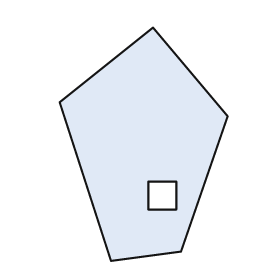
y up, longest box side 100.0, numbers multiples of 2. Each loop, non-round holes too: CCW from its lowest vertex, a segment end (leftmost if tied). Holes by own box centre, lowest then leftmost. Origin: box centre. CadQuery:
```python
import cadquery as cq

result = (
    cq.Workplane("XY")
    .moveTo(-14.0, -50.0)
    .lineTo(16.0, -46.0)
    .lineTo(36.0, 12.0)
    .lineTo(4.0, 50.0)
    .lineTo(-36.0, 18.0)
    .close()
    .moveTo(2.0, -28.0)
    .lineTo(14.0, -28.0)
    .lineTo(14.0, -16.0)
    .lineTo(2.0, -16.0)
    .close()
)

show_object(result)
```